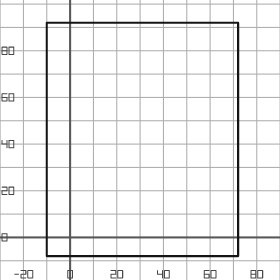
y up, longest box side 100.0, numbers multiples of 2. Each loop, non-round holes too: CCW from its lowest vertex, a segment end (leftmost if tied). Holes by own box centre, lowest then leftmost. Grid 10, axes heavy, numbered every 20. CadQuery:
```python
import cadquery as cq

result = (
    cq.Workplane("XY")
    .moveTo(-10.0, -8.0)
    .lineTo(72.0, -8.0)
    .lineTo(72.0, 92.0)
    .lineTo(-10.0, 92.0)
    .close()
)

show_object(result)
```